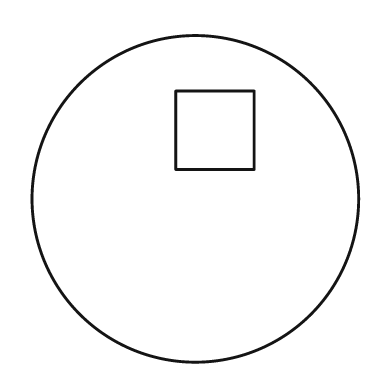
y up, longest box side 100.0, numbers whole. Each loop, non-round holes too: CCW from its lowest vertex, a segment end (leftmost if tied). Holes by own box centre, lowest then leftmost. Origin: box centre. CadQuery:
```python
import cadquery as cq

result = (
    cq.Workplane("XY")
    .moveTo(0.0, 0.0)
    .circle(50.0)
    .moveTo(-6.0, 9.0)
    .lineTo(18.0, 9.0)
    .lineTo(18.0, 33.0)
    .lineTo(-6.0, 33.0)
    .close()
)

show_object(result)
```